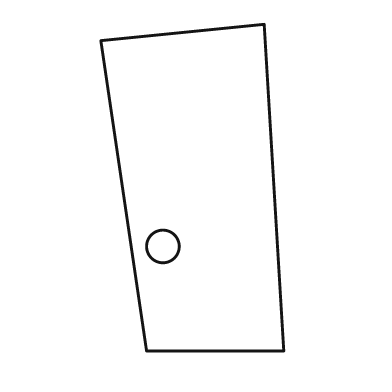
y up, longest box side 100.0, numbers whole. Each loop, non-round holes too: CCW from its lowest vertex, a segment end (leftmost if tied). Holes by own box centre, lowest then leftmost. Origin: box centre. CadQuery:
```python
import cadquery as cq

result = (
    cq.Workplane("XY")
    .moveTo(-14.0, -50.0)
    .lineTo(28.0, -50.0)
    .lineTo(22.0, 50.0)
    .lineTo(-28.0, 45.0)
    .close()
    .moveTo(-9.0, -18.0)
    .circle(5.0)
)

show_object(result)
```